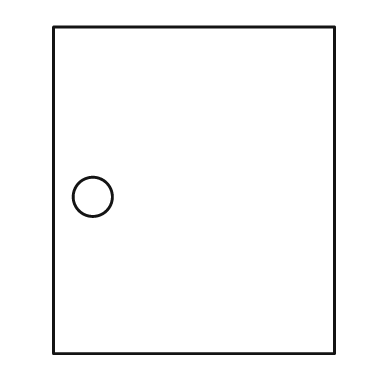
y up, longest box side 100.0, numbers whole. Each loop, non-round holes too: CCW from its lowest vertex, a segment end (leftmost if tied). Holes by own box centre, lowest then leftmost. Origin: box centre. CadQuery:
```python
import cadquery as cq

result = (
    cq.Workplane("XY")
    .moveTo(-43.0, -50.0)
    .lineTo(43.0, -50.0)
    .lineTo(43.0, 50.0)
    .lineTo(-43.0, 50.0)
    .close()
    .moveTo(-31.0, -2.0)
    .circle(6.0)
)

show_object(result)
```